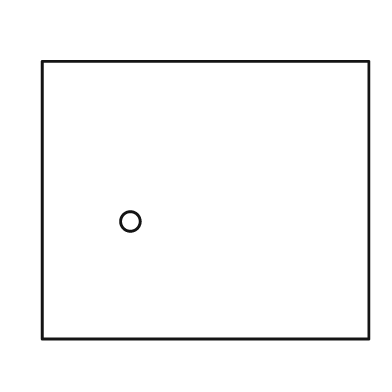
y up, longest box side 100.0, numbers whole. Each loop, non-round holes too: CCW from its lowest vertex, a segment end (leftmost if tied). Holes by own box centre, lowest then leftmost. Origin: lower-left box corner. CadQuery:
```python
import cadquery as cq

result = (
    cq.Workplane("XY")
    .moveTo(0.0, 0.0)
    .lineTo(100.0, 0.0)
    .lineTo(100.0, 85.0)
    .lineTo(0.0, 85.0)
    .close()
    .moveTo(27.0, 36.0)
    .circle(3.0)
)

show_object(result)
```